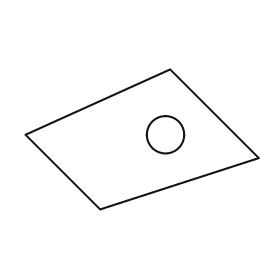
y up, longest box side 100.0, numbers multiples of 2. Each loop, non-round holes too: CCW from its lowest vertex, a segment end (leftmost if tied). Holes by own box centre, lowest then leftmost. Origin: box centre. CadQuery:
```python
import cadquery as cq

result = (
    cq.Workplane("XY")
    .moveTo(-18.0, -30.0)
    .lineTo(50.0, -8.0)
    .lineTo(12.0, 30.0)
    .lineTo(-50.0, 2.0)
    .close()
    .moveTo(10.0, 2.0)
    .circle(8.0)
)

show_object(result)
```